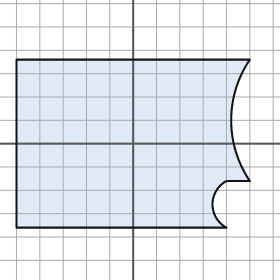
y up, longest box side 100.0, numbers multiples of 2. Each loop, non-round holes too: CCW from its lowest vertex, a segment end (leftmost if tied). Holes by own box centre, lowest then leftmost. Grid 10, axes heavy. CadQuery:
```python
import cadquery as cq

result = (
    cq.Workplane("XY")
    .moveTo(-50.0, -36.0)
    .lineTo(40.0, -36.0)
    .threePointArc((34.0, -26.0), (40.0, -16.0))
    .lineTo(50.0, -16.0)
    .threePointArc((42.0, 10.0), (50.0, 36.0))
    .lineTo(-50.0, 36.0)
    .close()
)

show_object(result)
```